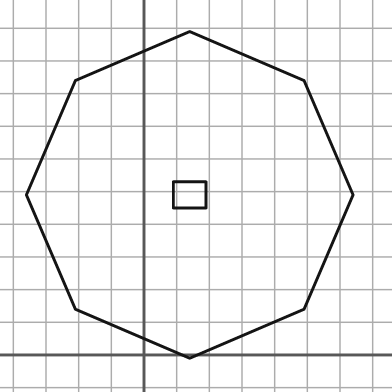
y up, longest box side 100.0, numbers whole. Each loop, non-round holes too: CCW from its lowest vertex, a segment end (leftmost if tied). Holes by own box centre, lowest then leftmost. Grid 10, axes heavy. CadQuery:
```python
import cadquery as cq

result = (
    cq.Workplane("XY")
    .moveTo(14.0, -1.0)
    .lineTo(49.0, 14.0)
    .lineTo(64.0, 49.0)
    .lineTo(49.0, 84.0)
    .lineTo(14.0, 99.0)
    .lineTo(-21.0, 84.0)
    .lineTo(-36.0, 49.0)
    .lineTo(-21.0, 14.0)
    .close()
    .moveTo(9.0, 45.0)
    .lineTo(19.0, 45.0)
    .lineTo(19.0, 53.0)
    .lineTo(9.0, 53.0)
    .close()
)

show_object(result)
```